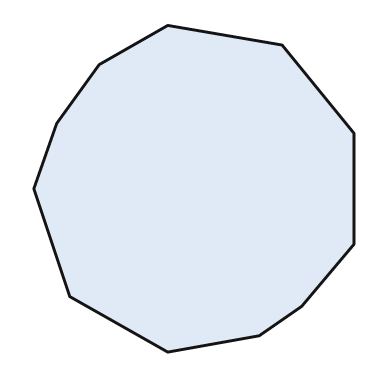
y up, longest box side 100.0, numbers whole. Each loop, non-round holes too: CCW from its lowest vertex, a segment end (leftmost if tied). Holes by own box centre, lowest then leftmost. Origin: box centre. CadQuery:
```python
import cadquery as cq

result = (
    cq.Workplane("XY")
    .moveTo(-8.0, -50.0)
    .lineTo(20.0, -45.0)
    .lineTo(33.0, -36.0)
    .lineTo(49.0, -17.0)
    .lineTo(49.0, 17.0)
    .lineTo(27.0, 44.0)
    .lineTo(-8.0, 50.0)
    .lineTo(-29.0, 38.0)
    .lineTo(-42.0, 20.0)
    .lineTo(-49.0, 0.0)
    .lineTo(-38.0, -33.0)
    .close()
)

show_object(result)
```